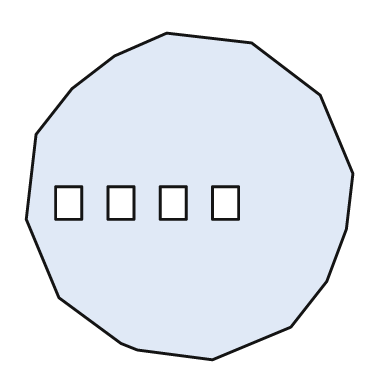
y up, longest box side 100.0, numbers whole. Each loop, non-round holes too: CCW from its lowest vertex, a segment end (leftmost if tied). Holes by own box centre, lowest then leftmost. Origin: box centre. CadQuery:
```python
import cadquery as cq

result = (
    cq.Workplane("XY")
    .moveTo(7.0, -50.0)
    .lineTo(31.0, -40.0)
    .lineTo(42.0, -26.0)
    .lineTo(48.0, -10.0)
    .lineTo(50.0, 7.0)
    .lineTo(40.0, 31.0)
    .lineTo(19.0, 47.0)
    .lineTo(-7.0, 50.0)
    .lineTo(-23.0, 43.0)
    .lineTo(-36.0, 33.0)
    .lineTo(-47.0, 19.0)
    .lineTo(-50.0, -7.0)
    .lineTo(-40.0, -31.0)
    .lineTo(-21.0, -45.0)
    .lineTo(-16.0, -47.0)
    .close()
    .moveTo(-41.0, -7.0)
    .lineTo(-33.0, -7.0)
    .lineTo(-33.0, 3.0)
    .lineTo(-41.0, 3.0)
    .close()
    .moveTo(-25.0, -7.0)
    .lineTo(-17.0, -7.0)
    .lineTo(-17.0, 3.0)
    .lineTo(-25.0, 3.0)
    .close()
    .moveTo(-9.0, -7.0)
    .lineTo(-1.0, -7.0)
    .lineTo(-1.0, 3.0)
    .lineTo(-9.0, 3.0)
    .close()
    .moveTo(7.0, -7.0)
    .lineTo(15.0, -7.0)
    .lineTo(15.0, 3.0)
    .lineTo(7.0, 3.0)
    .close()
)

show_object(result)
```